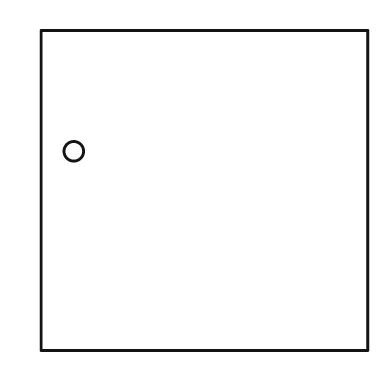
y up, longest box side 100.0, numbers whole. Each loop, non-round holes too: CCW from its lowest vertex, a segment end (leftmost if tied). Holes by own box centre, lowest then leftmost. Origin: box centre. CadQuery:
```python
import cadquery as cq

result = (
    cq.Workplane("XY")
    .moveTo(-50.0, -49.0)
    .lineTo(50.0, -49.0)
    .lineTo(50.0, 49.0)
    .lineTo(-50.0, 49.0)
    .close()
    .moveTo(-40.0, 12.0)
    .circle(3.0)
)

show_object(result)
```